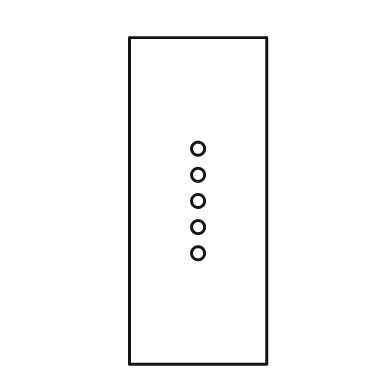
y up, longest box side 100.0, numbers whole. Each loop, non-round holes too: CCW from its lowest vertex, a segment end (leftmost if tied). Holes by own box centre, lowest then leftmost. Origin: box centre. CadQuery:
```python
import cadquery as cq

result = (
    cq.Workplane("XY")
    .moveTo(-21.0, -50.0)
    .lineTo(21.0, -50.0)
    .lineTo(21.0, 50.0)
    .lineTo(-21.0, 50.0)
    .close()
    .moveTo(0.0, -16.0)
    .circle(2.0)
    .moveTo(0.0, -8.0)
    .circle(2.0)
    .moveTo(0.0, 0.0)
    .circle(2.0)
    .moveTo(0.0, 8.0)
    .circle(2.0)
    .moveTo(0.0, 16.0)
    .circle(2.0)
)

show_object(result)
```